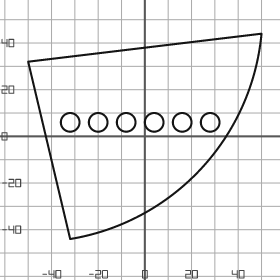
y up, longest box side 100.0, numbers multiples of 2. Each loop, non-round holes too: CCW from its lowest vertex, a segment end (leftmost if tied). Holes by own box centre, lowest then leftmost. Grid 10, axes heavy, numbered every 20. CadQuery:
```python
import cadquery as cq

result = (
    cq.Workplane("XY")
    .moveTo(-32.0, -44.0)
    .threePointArc((24.0, -14.0), (50.0, 44.0))
    .lineTo(-50.0, 32.0)
    .close()
    .moveTo(-32.0, 6.0)
    .circle(4.0)
    .moveTo(-20.0, 6.0)
    .circle(4.0)
    .moveTo(-8.0, 6.0)
    .circle(4.0)
    .moveTo(4.0, 6.0)
    .circle(4.0)
    .moveTo(16.0, 6.0)
    .circle(4.0)
    .moveTo(28.0, 6.0)
    .circle(4.0)
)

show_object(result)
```